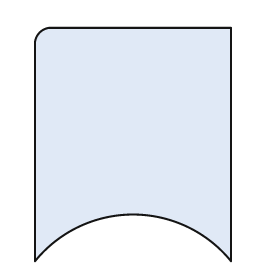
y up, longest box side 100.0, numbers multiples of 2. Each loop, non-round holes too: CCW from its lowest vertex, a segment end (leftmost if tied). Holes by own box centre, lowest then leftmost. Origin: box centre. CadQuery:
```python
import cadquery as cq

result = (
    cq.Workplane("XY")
    .moveTo(-42.0, -50.0)
    .threePointArc((0.0, -30.0), (42.0, -50.0))
    .lineTo(42.0, 50.0)
    .lineTo(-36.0, 50.0)
    .threePointArc((-40.0, 48.0), (-42.0, 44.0))
    .close()
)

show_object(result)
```